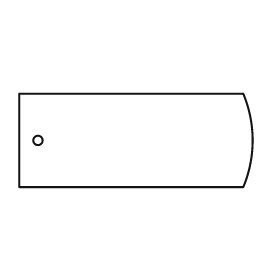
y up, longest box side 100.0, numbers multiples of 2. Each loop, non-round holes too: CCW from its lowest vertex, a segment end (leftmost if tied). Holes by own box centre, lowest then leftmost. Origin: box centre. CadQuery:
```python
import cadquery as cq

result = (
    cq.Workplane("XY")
    .moveTo(-50.0, -20.0)
    .lineTo(46.0, -20.0)
    .threePointArc((50.0, 0.0), (46.0, 20.0))
    .lineTo(-50.0, 20.0)
    .close()
    .moveTo(-42.0, 0.0)
    .circle(2.0)
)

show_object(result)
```